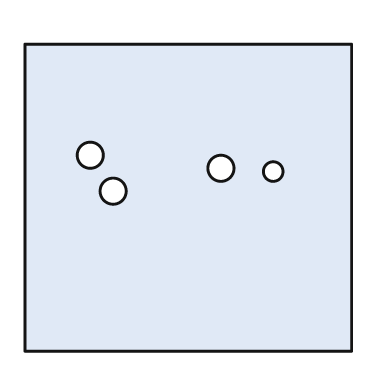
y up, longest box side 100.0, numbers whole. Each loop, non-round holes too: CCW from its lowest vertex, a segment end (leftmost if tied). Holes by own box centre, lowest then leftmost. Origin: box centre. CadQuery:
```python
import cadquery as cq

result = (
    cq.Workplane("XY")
    .moveTo(-50.0, -47.0)
    .lineTo(50.0, -47.0)
    .lineTo(50.0, 47.0)
    .lineTo(-50.0, 47.0)
    .close()
    .moveTo(-23.0, 2.0)
    .circle(4.0)
    .moveTo(26.0, 8.0)
    .circle(3.0)
    .moveTo(10.0, 9.0)
    .circle(4.0)
    .moveTo(-30.0, 13.0)
    .circle(4.0)
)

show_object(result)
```